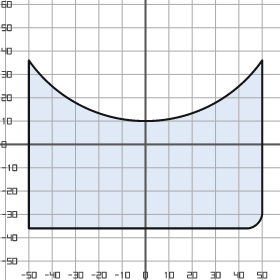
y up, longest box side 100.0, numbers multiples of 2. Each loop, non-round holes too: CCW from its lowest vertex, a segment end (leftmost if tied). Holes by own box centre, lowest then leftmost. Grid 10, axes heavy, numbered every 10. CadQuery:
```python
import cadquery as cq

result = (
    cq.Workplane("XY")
    .moveTo(-50.0, -36.0)
    .lineTo(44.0, -36.0)
    .threePointArc((48.0, -34.0), (50.0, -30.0))
    .lineTo(50.0, 36.0)
    .threePointArc((0.0, 10.0), (-50.0, 36.0))
    .close()
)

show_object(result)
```